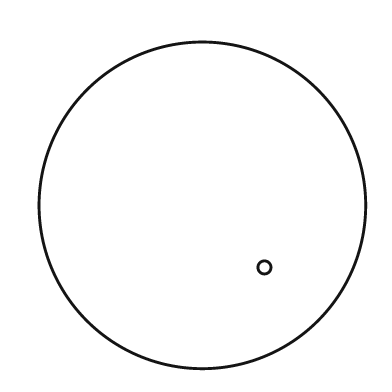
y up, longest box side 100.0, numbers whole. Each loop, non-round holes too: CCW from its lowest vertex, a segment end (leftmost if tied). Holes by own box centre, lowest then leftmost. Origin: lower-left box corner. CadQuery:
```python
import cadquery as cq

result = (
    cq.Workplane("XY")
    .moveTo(50.0, 50.0)
    .circle(50.0)
    .moveTo(69.0, 31.0)
    .circle(2.0)
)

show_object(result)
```